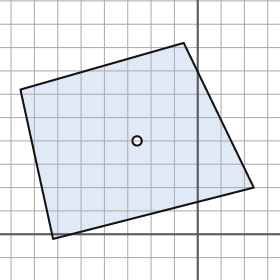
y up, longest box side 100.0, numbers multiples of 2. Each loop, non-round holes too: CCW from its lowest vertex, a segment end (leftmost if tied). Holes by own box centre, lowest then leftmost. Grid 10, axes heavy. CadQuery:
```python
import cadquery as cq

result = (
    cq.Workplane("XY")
    .moveTo(-62.0, -2.0)
    .lineTo(24.0, 20.0)
    .lineTo(-6.0, 82.0)
    .lineTo(-76.0, 62.0)
    .close()
    .moveTo(-26.0, 40.0)
    .circle(2.0)
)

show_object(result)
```